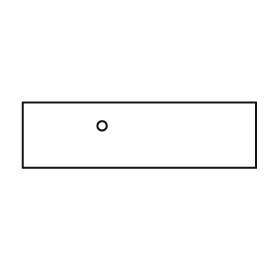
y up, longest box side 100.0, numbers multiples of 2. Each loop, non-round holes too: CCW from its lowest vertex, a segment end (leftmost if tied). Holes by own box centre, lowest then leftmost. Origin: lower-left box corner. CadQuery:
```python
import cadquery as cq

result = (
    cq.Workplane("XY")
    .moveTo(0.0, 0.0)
    .lineTo(100.0, 0.0)
    .lineTo(100.0, 28.0)
    .lineTo(0.0, 28.0)
    .close()
    .moveTo(34.0, 18.0)
    .circle(2.0)
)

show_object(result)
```